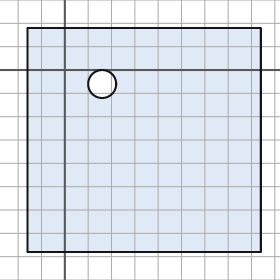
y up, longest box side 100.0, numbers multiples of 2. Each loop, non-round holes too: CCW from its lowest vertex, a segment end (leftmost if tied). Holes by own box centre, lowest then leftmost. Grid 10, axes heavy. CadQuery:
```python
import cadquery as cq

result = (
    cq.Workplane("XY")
    .moveTo(-16.0, -78.0)
    .lineTo(84.0, -78.0)
    .lineTo(84.0, 18.0)
    .lineTo(-16.0, 18.0)
    .close()
    .moveTo(16.0, -6.0)
    .circle(6.0)
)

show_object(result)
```